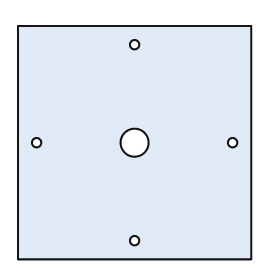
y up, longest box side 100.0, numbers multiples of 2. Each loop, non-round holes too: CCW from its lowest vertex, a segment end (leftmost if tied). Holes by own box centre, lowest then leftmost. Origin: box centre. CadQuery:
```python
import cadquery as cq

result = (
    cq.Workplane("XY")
    .moveTo(-50.0, -50.0)
    .lineTo(50.0, -50.0)
    .lineTo(50.0, 50.0)
    .lineTo(-50.0, 50.0)
    .close()
    .moveTo(0.0, -42.0)
    .circle(2.0)
    .moveTo(-42.0, 0.0)
    .circle(2.0)
    .moveTo(0.0, 0.0)
    .circle(6.0)
    .moveTo(42.0, 0.0)
    .circle(2.0)
    .moveTo(0.0, 42.0)
    .circle(2.0)
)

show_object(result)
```